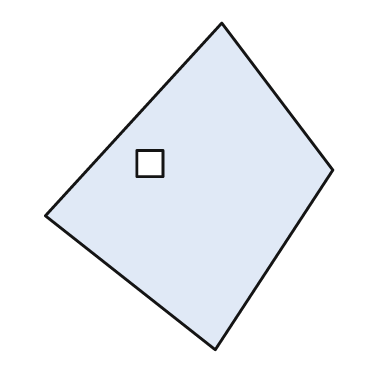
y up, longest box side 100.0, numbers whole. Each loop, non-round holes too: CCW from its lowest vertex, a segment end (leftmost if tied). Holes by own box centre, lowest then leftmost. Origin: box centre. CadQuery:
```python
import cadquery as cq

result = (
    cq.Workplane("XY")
    .moveTo(8.0, -50.0)
    .lineTo(44.0, 5.0)
    .lineTo(10.0, 50.0)
    .lineTo(-44.0, -9.0)
    .close()
    .moveTo(-16.0, 3.0)
    .lineTo(-8.0, 3.0)
    .lineTo(-8.0, 11.0)
    .lineTo(-16.0, 11.0)
    .close()
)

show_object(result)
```